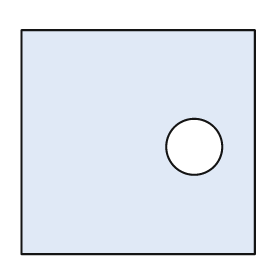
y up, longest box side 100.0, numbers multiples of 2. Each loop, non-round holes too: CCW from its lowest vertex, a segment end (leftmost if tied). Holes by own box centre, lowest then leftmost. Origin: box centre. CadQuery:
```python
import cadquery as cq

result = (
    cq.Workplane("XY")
    .moveTo(-50.0, -48.0)
    .lineTo(50.0, -48.0)
    .lineTo(50.0, 48.0)
    .lineTo(-50.0, 48.0)
    .close()
    .moveTo(24.0, -2.0)
    .circle(12.0)
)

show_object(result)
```